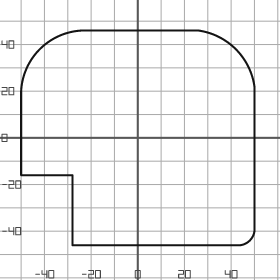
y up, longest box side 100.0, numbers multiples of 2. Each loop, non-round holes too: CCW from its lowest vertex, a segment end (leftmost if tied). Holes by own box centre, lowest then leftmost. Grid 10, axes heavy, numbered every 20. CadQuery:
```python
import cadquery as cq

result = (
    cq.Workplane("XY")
    .moveTo(-28.0, -46.0)
    .lineTo(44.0, -46.0)
    .threePointArc((48.0, -44.0), (50.0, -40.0))
    .lineTo(50.0, 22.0)
    .threePointArc((42.0, 38.0), (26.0, 46.0))
    .lineTo(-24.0, 46.0)
    .threePointArc((-42.0, 38.0), (-50.0, 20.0))
    .lineTo(-50.0, -16.0)
    .lineTo(-28.0, -16.0)
    .close()
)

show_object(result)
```